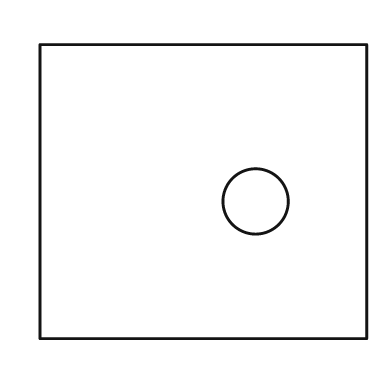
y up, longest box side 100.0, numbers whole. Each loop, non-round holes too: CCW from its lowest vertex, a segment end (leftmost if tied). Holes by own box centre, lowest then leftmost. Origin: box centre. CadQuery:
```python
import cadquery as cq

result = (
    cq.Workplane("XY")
    .moveTo(-50.0, -45.0)
    .lineTo(50.0, -45.0)
    .lineTo(50.0, 45.0)
    .lineTo(-50.0, 45.0)
    .close()
    .moveTo(16.0, -3.0)
    .circle(10.0)
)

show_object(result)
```